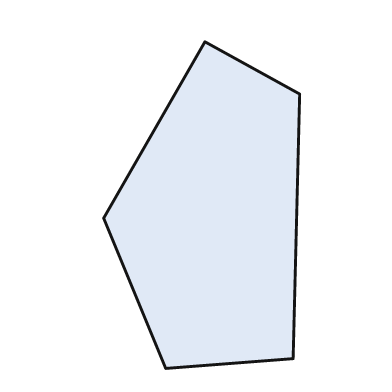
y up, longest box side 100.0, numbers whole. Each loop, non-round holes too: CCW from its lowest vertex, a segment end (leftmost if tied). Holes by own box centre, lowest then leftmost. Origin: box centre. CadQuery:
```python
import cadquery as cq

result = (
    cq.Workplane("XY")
    .moveTo(-11.0, -50.0)
    .lineTo(28.0, -47.0)
    .lineTo(30.0, 34.0)
    .lineTo(1.0, 50.0)
    .lineTo(-30.0, -4.0)
    .close()
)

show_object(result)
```